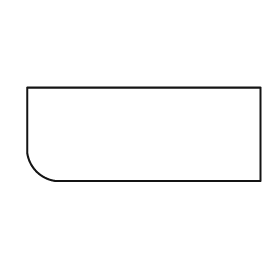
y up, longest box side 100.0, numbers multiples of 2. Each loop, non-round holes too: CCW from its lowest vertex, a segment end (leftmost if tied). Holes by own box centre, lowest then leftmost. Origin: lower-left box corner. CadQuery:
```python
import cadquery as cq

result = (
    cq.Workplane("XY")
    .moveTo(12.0, 0.0)
    .lineTo(100.0, 0.0)
    .lineTo(100.0, 40.0)
    .lineTo(0.0, 40.0)
    .lineTo(0.0, 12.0)
    .threePointArc((4.0, 4.0), (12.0, 0.0))
    .close()
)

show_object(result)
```